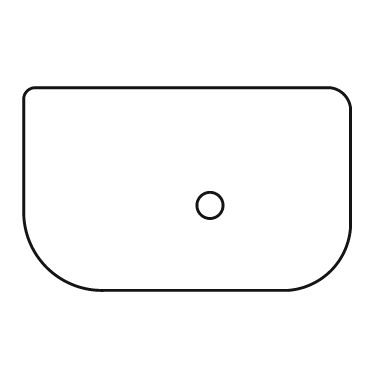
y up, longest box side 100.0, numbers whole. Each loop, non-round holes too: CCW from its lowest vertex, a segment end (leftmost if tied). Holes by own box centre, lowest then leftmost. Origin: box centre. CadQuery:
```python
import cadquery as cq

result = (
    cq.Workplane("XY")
    .moveTo(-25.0, -31.0)
    .lineTo(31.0, -31.0)
    .threePointArc((44.0, -25.0), (50.0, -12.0))
    .lineTo(50.0, 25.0)
    .threePointArc((48.0, 29.0), (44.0, 31.0))
    .lineTo(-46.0, 31.0)
    .threePointArc((-49.0, 30.0), (-50.0, 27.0))
    .lineTo(-50.0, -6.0)
    .threePointArc((-43.0, -24.0), (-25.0, -31.0))
    .close()
    .moveTo(7.0, -5.0)
    .circle(4.0)
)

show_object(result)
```